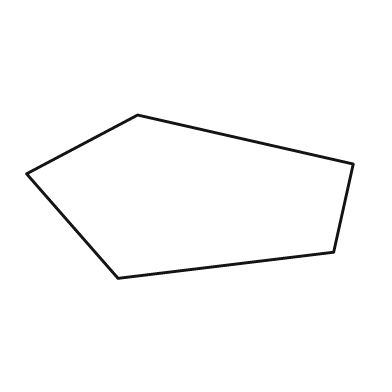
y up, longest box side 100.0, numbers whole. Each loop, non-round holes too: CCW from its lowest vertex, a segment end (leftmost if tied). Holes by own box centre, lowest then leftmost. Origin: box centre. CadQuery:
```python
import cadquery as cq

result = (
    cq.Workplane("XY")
    .moveTo(-22.0, -25.0)
    .lineTo(44.0, -17.0)
    .lineTo(50.0, 10.0)
    .lineTo(-16.0, 25.0)
    .lineTo(-50.0, 7.0)
    .close()
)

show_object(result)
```